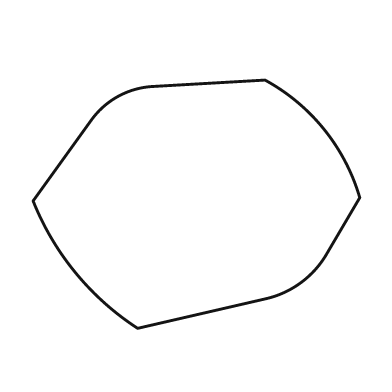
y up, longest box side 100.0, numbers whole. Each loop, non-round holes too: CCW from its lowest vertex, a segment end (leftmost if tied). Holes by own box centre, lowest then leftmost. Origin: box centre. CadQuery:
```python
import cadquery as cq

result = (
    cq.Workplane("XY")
    .moveTo(-18.0, -38.0)
    .lineTo(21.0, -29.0)
    .threePointArc((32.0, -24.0), (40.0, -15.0))
    .lineTo(50.0, 2.0)
    .threePointArc((39.0, 23.0), (21.0, 38.0))
    .lineTo(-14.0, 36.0)
    .threePointArc((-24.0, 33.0), (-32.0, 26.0))
    .lineTo(-50.0, 1.0)
    .threePointArc((-37.0, -21.0), (-18.0, -38.0))
    .close()
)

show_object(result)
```